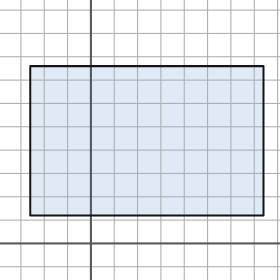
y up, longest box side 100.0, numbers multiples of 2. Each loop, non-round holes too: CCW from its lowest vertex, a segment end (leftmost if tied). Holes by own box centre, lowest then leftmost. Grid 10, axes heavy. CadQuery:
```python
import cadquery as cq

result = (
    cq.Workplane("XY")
    .moveTo(-26.0, 12.0)
    .lineTo(74.0, 12.0)
    .lineTo(74.0, 76.0)
    .lineTo(-26.0, 76.0)
    .close()
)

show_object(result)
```